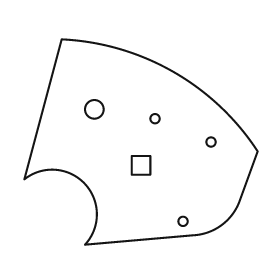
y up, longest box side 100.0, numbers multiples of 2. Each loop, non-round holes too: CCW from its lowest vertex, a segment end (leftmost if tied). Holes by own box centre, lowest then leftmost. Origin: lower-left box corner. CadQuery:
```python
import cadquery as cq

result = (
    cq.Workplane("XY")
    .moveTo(26.0, 0.0)
    .lineTo(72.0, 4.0)
    .threePointArc((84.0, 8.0), (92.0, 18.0))
    .lineTo(100.0, 40.0)
    .threePointArc((64.0, 74.0), (16.0, 88.0))
    .lineTo(0.0, 28.0)
    .threePointArc((26.0, 26.0), (26.0, 0.0))
    .close()
    .moveTo(68.0, 10.0)
    .circle(2.0)
    .moveTo(46.0, 30.0)
    .lineTo(54.0, 30.0)
    .lineTo(54.0, 38.0)
    .lineTo(46.0, 38.0)
    .close()
    .moveTo(80.0, 44.0)
    .circle(2.0)
    .moveTo(56.0, 54.0)
    .circle(2.0)
    .moveTo(30.0, 58.0)
    .circle(4.0)
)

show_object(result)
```